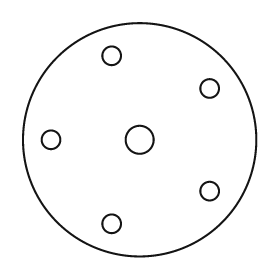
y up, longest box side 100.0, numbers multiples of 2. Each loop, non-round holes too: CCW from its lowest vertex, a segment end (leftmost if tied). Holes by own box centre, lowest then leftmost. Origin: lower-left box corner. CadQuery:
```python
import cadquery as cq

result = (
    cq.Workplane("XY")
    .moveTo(50.0, 50.0)
    .circle(50.0)
    .moveTo(38.0, 14.0)
    .circle(4.0)
    .moveTo(80.0, 28.0)
    .circle(4.0)
    .moveTo(12.0, 50.0)
    .circle(4.0)
    .moveTo(50.0, 50.0)
    .circle(6.0)
    .moveTo(80.0, 72.0)
    .circle(4.0)
    .moveTo(38.0, 86.0)
    .circle(4.0)
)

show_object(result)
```